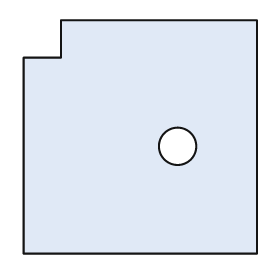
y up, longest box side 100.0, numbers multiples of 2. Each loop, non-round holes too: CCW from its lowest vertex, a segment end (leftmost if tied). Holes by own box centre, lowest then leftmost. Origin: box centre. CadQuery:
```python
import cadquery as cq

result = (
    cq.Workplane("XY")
    .moveTo(-50.0, -50.0)
    .lineTo(50.0, -50.0)
    .lineTo(50.0, 50.0)
    .lineTo(-34.0, 50.0)
    .lineTo(-34.0, 34.0)
    .lineTo(-50.0, 34.0)
    .close()
    .moveTo(16.0, -4.0)
    .circle(8.0)
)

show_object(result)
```